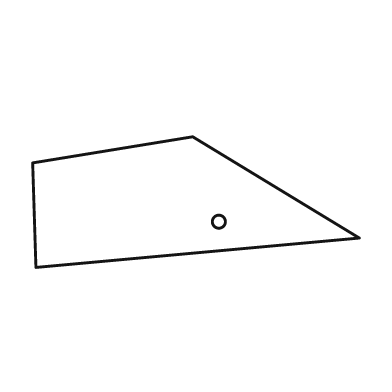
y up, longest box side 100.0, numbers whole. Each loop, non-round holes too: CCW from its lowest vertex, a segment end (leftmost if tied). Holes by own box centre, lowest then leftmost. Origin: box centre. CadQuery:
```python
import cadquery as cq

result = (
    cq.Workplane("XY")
    .moveTo(-49.0, -20.0)
    .lineTo(50.0, -11.0)
    .lineTo(-1.0, 20.0)
    .lineTo(-50.0, 12.0)
    .close()
    .moveTo(7.0, -6.0)
    .circle(2.0)
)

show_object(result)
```